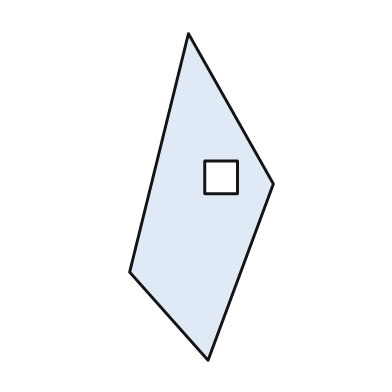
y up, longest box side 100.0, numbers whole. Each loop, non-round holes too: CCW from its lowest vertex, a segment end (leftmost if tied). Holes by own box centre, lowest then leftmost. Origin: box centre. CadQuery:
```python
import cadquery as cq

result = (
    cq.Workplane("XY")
    .moveTo(2.0, -50.0)
    .lineTo(22.0, 4.0)
    .lineTo(-4.0, 50.0)
    .lineTo(-22.0, -23.0)
    .close()
    .moveTo(1.0, 1.0)
    .lineTo(11.0, 1.0)
    .lineTo(11.0, 11.0)
    .lineTo(1.0, 11.0)
    .close()
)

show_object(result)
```